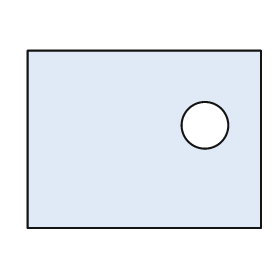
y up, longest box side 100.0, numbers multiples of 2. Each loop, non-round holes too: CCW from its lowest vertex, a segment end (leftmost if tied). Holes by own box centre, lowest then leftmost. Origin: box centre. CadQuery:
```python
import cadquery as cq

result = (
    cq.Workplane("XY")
    .moveTo(-50.0, -38.0)
    .lineTo(50.0, -38.0)
    .lineTo(50.0, 38.0)
    .lineTo(-50.0, 38.0)
    .close()
    .moveTo(26.0, 6.0)
    .circle(10.0)
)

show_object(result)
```